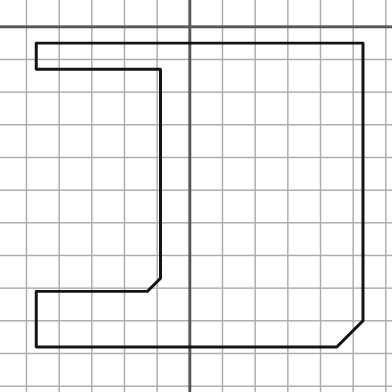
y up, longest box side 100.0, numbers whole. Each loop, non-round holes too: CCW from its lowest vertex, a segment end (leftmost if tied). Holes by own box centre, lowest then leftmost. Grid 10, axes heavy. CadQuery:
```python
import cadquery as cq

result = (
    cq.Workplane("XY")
    .moveTo(-47.0, -98.0)
    .lineTo(45.0, -98.0)
    .lineTo(53.0, -90.0)
    .lineTo(53.0, -5.0)
    .lineTo(-47.0, -5.0)
    .lineTo(-47.0, -13.0)
    .lineTo(-9.0, -13.0)
    .lineTo(-9.0, -77.0)
    .lineTo(-13.0, -81.0)
    .lineTo(-47.0, -81.0)
    .close()
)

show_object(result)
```